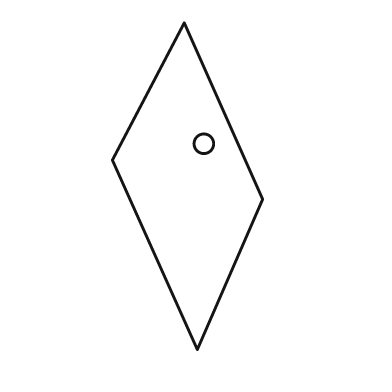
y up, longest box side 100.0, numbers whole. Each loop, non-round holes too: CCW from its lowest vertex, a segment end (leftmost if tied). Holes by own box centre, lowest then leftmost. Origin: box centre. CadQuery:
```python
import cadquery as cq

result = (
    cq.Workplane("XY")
    .moveTo(3.0, -50.0)
    .lineTo(23.0, -4.0)
    .lineTo(-1.0, 50.0)
    .lineTo(-23.0, 8.0)
    .close()
    .moveTo(5.0, 13.0)
    .circle(3.0)
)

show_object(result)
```